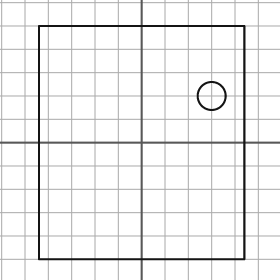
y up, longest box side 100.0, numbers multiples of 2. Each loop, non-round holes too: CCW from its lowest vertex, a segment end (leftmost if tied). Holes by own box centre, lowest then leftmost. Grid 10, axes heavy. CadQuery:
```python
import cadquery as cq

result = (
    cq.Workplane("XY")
    .moveTo(-44.0, -50.0)
    .lineTo(44.0, -50.0)
    .lineTo(44.0, 50.0)
    .lineTo(-44.0, 50.0)
    .close()
    .moveTo(30.0, 20.0)
    .circle(6.0)
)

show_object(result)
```